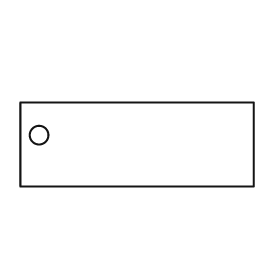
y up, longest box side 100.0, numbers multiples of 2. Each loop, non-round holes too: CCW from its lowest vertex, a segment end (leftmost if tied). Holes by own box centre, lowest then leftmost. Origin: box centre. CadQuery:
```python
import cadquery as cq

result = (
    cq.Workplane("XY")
    .moveTo(-50.0, -18.0)
    .lineTo(50.0, -18.0)
    .lineTo(50.0, 18.0)
    .lineTo(-50.0, 18.0)
    .close()
    .moveTo(-42.0, 4.0)
    .circle(4.0)
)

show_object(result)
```